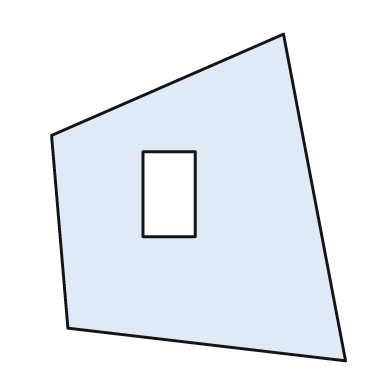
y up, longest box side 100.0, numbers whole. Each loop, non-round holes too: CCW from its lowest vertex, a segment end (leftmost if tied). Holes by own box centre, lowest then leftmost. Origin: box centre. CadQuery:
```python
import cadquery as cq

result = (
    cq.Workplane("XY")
    .moveTo(45.0, -50.0)
    .lineTo(26.0, 50.0)
    .lineTo(-45.0, 19.0)
    .lineTo(-40.0, -40.0)
    .close()
    .moveTo(-17.0, -12.0)
    .lineTo(-1.0, -12.0)
    .lineTo(-1.0, 14.0)
    .lineTo(-17.0, 14.0)
    .close()
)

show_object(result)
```